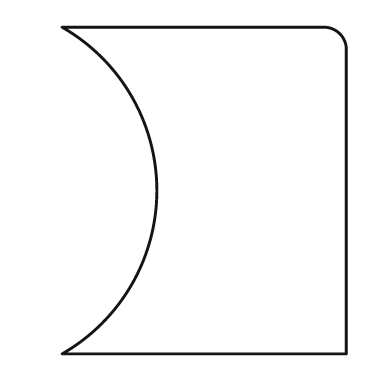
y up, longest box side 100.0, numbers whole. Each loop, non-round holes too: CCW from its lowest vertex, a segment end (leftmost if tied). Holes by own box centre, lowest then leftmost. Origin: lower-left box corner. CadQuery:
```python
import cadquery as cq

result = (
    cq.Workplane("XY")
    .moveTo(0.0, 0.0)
    .lineTo(87.0, 0.0)
    .lineTo(87.0, 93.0)
    .threePointArc((85.0, 98.0), (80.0, 100.0))
    .lineTo(0.0, 100.0)
    .threePointArc((29.0, 50.0), (0.0, 0.0))
    .close()
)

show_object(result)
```